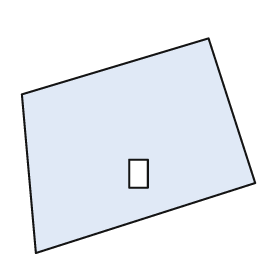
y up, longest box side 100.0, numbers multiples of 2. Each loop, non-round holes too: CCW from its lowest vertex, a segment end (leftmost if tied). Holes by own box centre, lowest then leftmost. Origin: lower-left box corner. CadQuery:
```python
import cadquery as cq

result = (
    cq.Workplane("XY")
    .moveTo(6.0, 0.0)
    .lineTo(100.0, 30.0)
    .lineTo(80.0, 92.0)
    .lineTo(0.0, 68.0)
    .close()
    .moveTo(46.0, 28.0)
    .lineTo(54.0, 28.0)
    .lineTo(54.0, 40.0)
    .lineTo(46.0, 40.0)
    .close()
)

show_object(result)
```